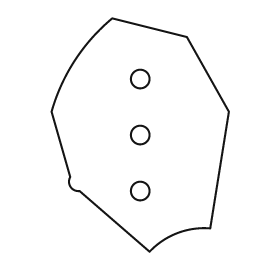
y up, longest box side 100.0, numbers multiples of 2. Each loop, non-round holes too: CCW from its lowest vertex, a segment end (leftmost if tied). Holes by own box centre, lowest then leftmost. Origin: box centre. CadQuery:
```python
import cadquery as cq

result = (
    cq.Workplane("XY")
    .moveTo(4.0, -50.0)
    .threePointArc((16.0, -42.0), (30.0, -40.0))
    .lineTo(38.0, 10.0)
    .lineTo(20.0, 42.0)
    .lineTo(-12.0, 50.0)
    .threePointArc((-28.0, 32.0), (-38.0, 10.0))
    .lineTo(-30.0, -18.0)
    .threePointArc((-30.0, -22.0), (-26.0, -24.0))
    .close()
    .moveTo(0.0, -24.0)
    .circle(4.0)
    .moveTo(0.0, 0.0)
    .circle(4.0)
    .moveTo(0.0, 24.0)
    .circle(4.0)
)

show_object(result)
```